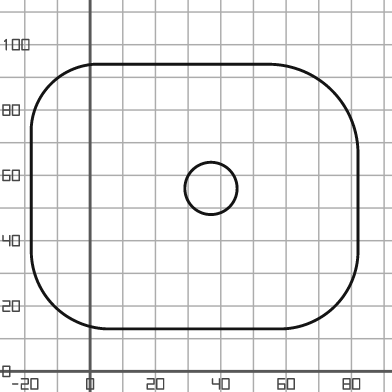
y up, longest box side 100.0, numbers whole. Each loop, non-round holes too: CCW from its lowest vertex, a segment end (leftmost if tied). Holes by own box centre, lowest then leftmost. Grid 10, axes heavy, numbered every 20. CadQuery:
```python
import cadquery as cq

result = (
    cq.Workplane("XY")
    .moveTo(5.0, 13.0)
    .lineTo(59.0, 13.0)
    .threePointArc((75.0, 20.0), (82.0, 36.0))
    .lineTo(82.0, 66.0)
    .threePointArc((74.0, 86.0), (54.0, 94.0))
    .lineTo(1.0, 94.0)
    .threePointArc((-12.0, 88.0), (-18.0, 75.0))
    .lineTo(-18.0, 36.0)
    .threePointArc((-11.0, 20.0), (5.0, 13.0))
    .close()
    .moveTo(37.0, 56.0)
    .circle(8.0)
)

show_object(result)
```